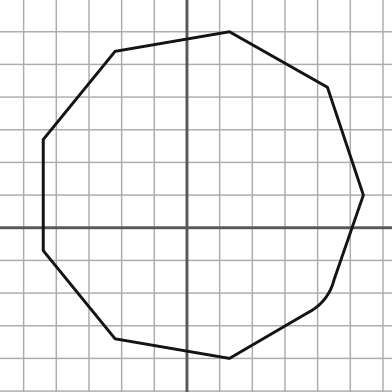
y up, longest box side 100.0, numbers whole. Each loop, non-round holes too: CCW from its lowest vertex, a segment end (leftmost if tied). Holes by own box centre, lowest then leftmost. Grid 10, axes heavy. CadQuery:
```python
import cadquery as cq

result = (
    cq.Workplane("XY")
    .moveTo(13.0, -40.0)
    .lineTo(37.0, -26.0)
    .threePointArc((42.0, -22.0), (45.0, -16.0))
    .lineTo(54.0, 10.0)
    .lineTo(43.0, 43.0)
    .lineTo(13.0, 60.0)
    .lineTo(-22.0, 54.0)
    .lineTo(-44.0, 27.0)
    .lineTo(-44.0, -7.0)
    .lineTo(-22.0, -34.0)
    .close()
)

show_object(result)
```